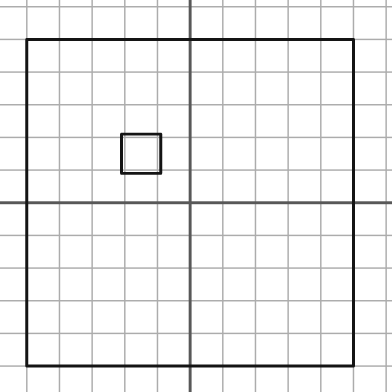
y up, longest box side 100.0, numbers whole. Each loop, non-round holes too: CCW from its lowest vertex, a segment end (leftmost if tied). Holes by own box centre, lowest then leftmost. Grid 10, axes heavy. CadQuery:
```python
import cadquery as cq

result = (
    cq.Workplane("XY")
    .moveTo(-50.0, -50.0)
    .lineTo(50.0, -50.0)
    .lineTo(50.0, 50.0)
    .lineTo(-50.0, 50.0)
    .close()
    .moveTo(-21.0, 9.0)
    .lineTo(-9.0, 9.0)
    .lineTo(-9.0, 21.0)
    .lineTo(-21.0, 21.0)
    .close()
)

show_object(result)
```